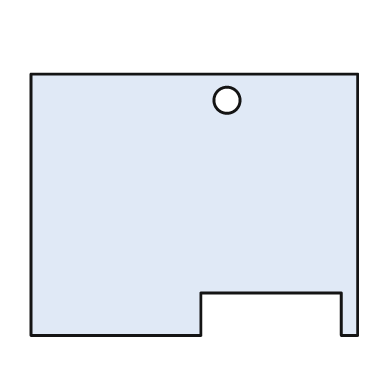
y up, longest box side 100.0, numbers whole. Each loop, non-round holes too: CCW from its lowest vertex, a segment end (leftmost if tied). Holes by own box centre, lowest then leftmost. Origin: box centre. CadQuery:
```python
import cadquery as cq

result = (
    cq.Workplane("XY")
    .moveTo(-50.0, -40.0)
    .lineTo(2.0, -40.0)
    .lineTo(2.0, -27.0)
    .lineTo(45.0, -27.0)
    .lineTo(45.0, -40.0)
    .lineTo(50.0, -40.0)
    .lineTo(50.0, 40.0)
    .lineTo(-50.0, 40.0)
    .close()
    .moveTo(10.0, 32.0)
    .circle(4.0)
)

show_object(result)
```